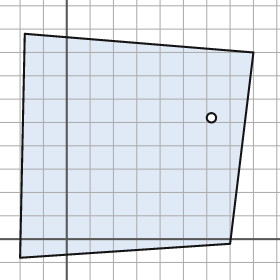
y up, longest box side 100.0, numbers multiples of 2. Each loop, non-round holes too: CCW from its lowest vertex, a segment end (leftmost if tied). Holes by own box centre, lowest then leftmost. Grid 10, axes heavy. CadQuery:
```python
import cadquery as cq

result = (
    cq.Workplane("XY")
    .moveTo(-20.0, -8.0)
    .lineTo(70.0, -2.0)
    .lineTo(80.0, 80.0)
    .lineTo(-18.0, 88.0)
    .close()
    .moveTo(62.0, 52.0)
    .circle(2.0)
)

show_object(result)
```